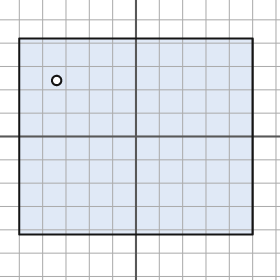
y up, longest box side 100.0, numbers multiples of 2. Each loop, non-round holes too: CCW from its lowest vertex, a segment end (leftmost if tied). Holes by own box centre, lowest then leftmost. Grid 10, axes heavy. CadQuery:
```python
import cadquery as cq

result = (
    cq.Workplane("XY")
    .moveTo(-50.0, -42.0)
    .lineTo(50.0, -42.0)
    .lineTo(50.0, 42.0)
    .lineTo(-50.0, 42.0)
    .close()
    .moveTo(-34.0, 24.0)
    .circle(2.0)
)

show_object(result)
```